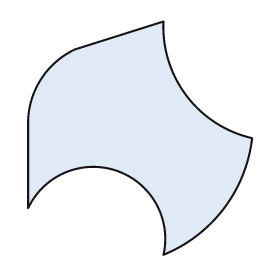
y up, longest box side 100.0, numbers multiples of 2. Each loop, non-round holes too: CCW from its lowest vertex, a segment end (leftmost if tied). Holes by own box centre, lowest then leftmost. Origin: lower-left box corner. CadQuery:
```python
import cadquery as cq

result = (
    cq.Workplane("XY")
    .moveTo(58.0, 0.0)
    .threePointArc((84.0, 20.0), (96.0, 50.0))
    .threePointArc((68.0, 68.0), (58.0, 100.0))
    .lineTo(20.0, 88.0)
    .threePointArc((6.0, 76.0), (0.0, 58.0))
    .lineTo(0.0, 20.0)
    .threePointArc((38.0, 36.0), (58.0, 0.0))
    .close()
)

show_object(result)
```